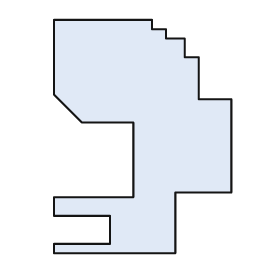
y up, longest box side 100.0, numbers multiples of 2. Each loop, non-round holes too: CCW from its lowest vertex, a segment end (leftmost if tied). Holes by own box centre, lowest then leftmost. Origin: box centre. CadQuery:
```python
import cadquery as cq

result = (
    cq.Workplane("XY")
    .moveTo(-38.0, -50.0)
    .lineTo(14.0, -50.0)
    .lineTo(14.0, -24.0)
    .lineTo(38.0, -24.0)
    .lineTo(38.0, 16.0)
    .lineTo(24.0, 16.0)
    .lineTo(24.0, 34.0)
    .lineTo(18.0, 34.0)
    .lineTo(18.0, 42.0)
    .lineTo(10.0, 42.0)
    .lineTo(10.0, 46.0)
    .lineTo(4.0, 46.0)
    .lineTo(4.0, 50.0)
    .lineTo(-38.0, 50.0)
    .lineTo(-38.0, 18.0)
    .lineTo(-26.0, 6.0)
    .lineTo(-4.0, 6.0)
    .lineTo(-4.0, -26.0)
    .lineTo(-38.0, -26.0)
    .lineTo(-38.0, -34.0)
    .lineTo(-14.0, -34.0)
    .lineTo(-14.0, -46.0)
    .lineTo(-38.0, -46.0)
    .close()
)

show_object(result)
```